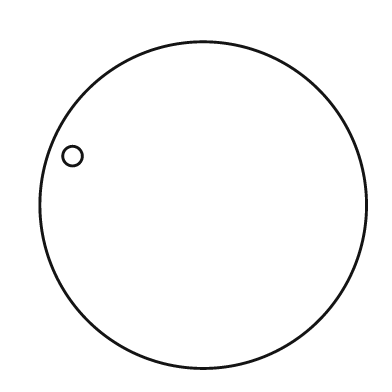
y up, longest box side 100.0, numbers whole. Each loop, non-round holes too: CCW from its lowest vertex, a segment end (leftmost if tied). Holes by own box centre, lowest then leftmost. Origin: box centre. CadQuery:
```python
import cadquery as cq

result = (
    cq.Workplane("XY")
    .moveTo(0.0, 0.0)
    .circle(50.0)
    .moveTo(-40.0, 15.0)
    .circle(3.0)
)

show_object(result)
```